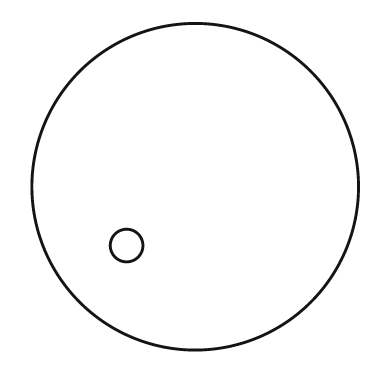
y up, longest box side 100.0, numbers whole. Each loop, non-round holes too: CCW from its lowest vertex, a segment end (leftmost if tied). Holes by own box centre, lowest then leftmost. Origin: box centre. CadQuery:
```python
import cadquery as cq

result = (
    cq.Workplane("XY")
    .moveTo(0.0, 0.0)
    .circle(50.0)
    .moveTo(-21.0, -18.0)
    .circle(5.0)
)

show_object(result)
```